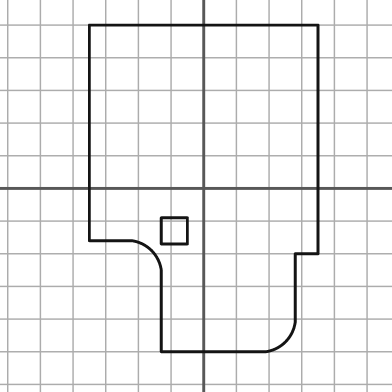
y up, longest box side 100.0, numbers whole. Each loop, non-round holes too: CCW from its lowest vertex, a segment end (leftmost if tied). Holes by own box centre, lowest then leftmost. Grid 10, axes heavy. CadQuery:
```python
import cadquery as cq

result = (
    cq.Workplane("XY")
    .moveTo(-13.0, -50.0)
    .lineTo(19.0, -50.0)
    .threePointArc((25.0, -47.0), (28.0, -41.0))
    .lineTo(28.0, -20.0)
    .lineTo(35.0, -20.0)
    .lineTo(35.0, 50.0)
    .lineTo(-35.0, 50.0)
    .lineTo(-35.0, -16.0)
    .lineTo(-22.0, -16.0)
    .threePointArc((-16.0, -19.0), (-13.0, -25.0))
    .close()
    .moveTo(-13.0, -17.0)
    .lineTo(-5.0, -17.0)
    .lineTo(-5.0, -9.0)
    .lineTo(-13.0, -9.0)
    .close()
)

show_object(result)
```